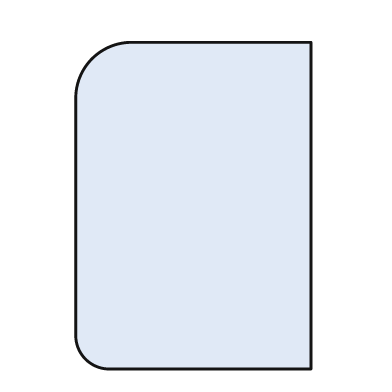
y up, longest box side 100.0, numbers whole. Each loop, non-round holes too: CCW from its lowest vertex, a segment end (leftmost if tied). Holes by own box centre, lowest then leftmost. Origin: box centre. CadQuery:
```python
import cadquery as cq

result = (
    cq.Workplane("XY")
    .moveTo(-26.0, -50.0)
    .lineTo(36.0, -50.0)
    .lineTo(36.0, 50.0)
    .lineTo(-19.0, 50.0)
    .threePointArc((-31.0, 45.0), (-36.0, 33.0))
    .lineTo(-36.0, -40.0)
    .threePointArc((-33.0, -47.0), (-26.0, -50.0))
    .close()
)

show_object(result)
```